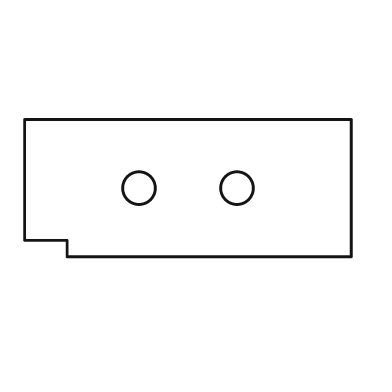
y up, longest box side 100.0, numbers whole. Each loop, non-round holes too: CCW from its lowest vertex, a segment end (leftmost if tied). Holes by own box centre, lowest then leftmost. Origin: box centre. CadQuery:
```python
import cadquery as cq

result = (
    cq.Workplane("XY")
    .moveTo(-37.0, -21.0)
    .lineTo(50.0, -21.0)
    .lineTo(50.0, 21.0)
    .lineTo(-50.0, 21.0)
    .lineTo(-50.0, -16.0)
    .lineTo(-37.0, -16.0)
    .close()
    .moveTo(-15.0, 0.0)
    .circle(5.0)
    .moveTo(15.0, 0.0)
    .circle(5.0)
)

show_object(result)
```